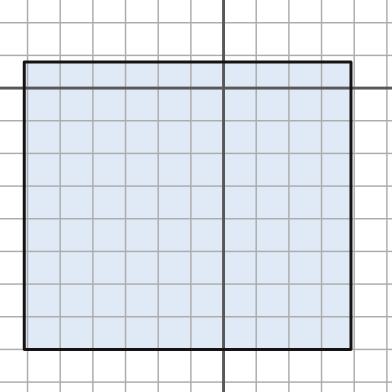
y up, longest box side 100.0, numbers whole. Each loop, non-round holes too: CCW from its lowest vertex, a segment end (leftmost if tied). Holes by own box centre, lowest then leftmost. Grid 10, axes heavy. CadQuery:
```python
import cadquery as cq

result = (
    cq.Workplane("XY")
    .moveTo(-61.0, -80.0)
    .lineTo(39.0, -80.0)
    .lineTo(39.0, 8.0)
    .lineTo(-61.0, 8.0)
    .close()
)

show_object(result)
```